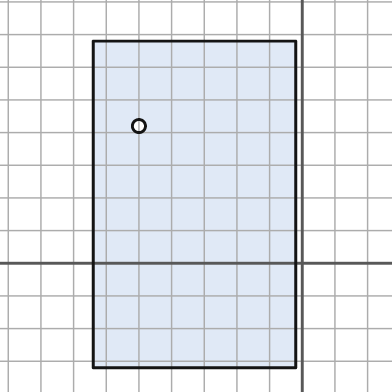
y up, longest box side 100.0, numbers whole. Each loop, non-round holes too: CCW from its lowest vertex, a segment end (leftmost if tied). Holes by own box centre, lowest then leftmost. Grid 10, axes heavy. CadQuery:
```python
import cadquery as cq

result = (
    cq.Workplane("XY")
    .moveTo(-64.0, -32.0)
    .lineTo(-2.0, -32.0)
    .lineTo(-2.0, 68.0)
    .lineTo(-64.0, 68.0)
    .close()
    .moveTo(-50.0, 42.0)
    .circle(2.0)
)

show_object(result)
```